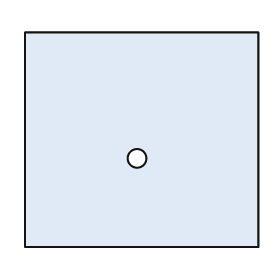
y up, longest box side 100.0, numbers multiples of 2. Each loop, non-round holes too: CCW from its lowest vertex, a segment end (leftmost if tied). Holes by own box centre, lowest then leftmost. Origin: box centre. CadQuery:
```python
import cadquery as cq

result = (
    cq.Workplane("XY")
    .moveTo(-50.0, -46.0)
    .lineTo(50.0, -46.0)
    .lineTo(50.0, 46.0)
    .lineTo(-50.0, 46.0)
    .close()
    .moveTo(-2.0, -8.0)
    .circle(4.0)
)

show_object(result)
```